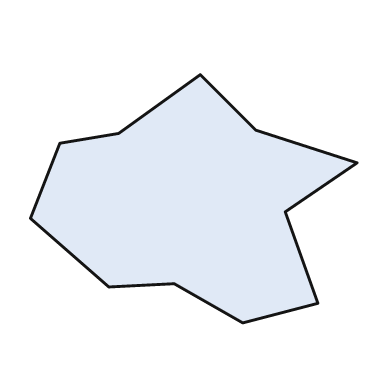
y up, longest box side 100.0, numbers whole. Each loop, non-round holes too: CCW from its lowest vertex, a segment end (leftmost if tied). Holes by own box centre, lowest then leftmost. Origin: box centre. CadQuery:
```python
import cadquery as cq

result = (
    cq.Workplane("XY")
    .moveTo(15.0, -38.0)
    .lineTo(38.0, -32.0)
    .lineTo(28.0, -4.0)
    .lineTo(50.0, 11.0)
    .lineTo(19.0, 21.0)
    .lineTo(2.0, 38.0)
    .lineTo(-23.0, 20.0)
    .lineTo(-41.0, 17.0)
    .lineTo(-50.0, -6.0)
    .lineTo(-26.0, -27.0)
    .lineTo(-6.0, -26.0)
    .close()
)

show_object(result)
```